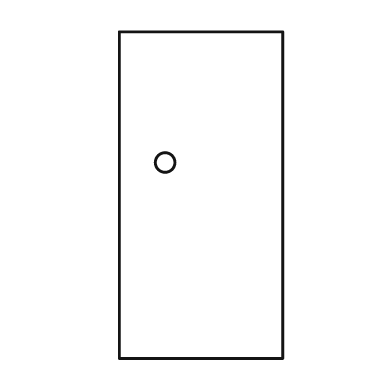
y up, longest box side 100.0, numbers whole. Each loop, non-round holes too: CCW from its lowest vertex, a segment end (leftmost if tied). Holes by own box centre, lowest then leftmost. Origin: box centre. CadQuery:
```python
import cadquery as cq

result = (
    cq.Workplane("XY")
    .moveTo(-25.0, -50.0)
    .lineTo(25.0, -50.0)
    .lineTo(25.0, 50.0)
    .lineTo(-25.0, 50.0)
    .close()
    .moveTo(-11.0, 10.0)
    .circle(3.0)
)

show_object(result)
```